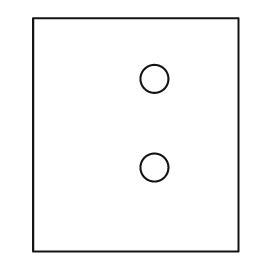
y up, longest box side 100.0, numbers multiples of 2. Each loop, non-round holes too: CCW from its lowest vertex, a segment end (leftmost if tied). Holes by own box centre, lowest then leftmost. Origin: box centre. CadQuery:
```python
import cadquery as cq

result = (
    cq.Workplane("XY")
    .moveTo(-44.0, -50.0)
    .lineTo(44.0, -50.0)
    .lineTo(44.0, 50.0)
    .lineTo(-44.0, 50.0)
    .close()
    .moveTo(8.0, -14.0)
    .circle(6.0)
    .moveTo(8.0, 24.0)
    .circle(6.0)
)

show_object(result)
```